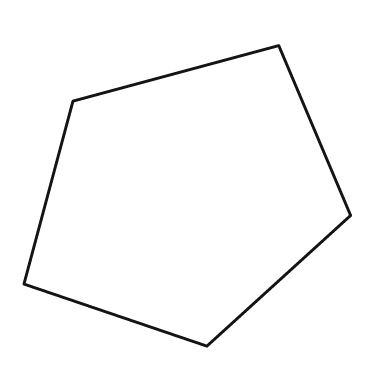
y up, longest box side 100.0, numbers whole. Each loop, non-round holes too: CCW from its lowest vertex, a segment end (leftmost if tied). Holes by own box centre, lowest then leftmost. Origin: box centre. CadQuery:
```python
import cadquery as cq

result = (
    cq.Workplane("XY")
    .moveTo(6.0, -46.0)
    .lineTo(50.0, -6.0)
    .lineTo(28.0, 46.0)
    .lineTo(-35.0, 29.0)
    .lineTo(-50.0, -27.0)
    .close()
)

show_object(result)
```